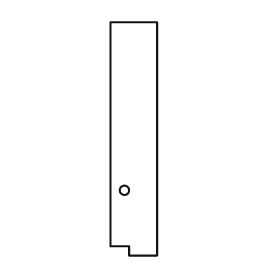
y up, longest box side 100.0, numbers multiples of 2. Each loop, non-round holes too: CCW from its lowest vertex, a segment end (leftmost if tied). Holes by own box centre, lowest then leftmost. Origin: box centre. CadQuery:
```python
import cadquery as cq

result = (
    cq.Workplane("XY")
    .moveTo(-2.0, -50.0)
    .lineTo(10.0, -50.0)
    .lineTo(10.0, 50.0)
    .lineTo(-10.0, 50.0)
    .lineTo(-10.0, -46.0)
    .lineTo(-2.0, -46.0)
    .close()
    .moveTo(-4.0, -22.0)
    .circle(2.0)
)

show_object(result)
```